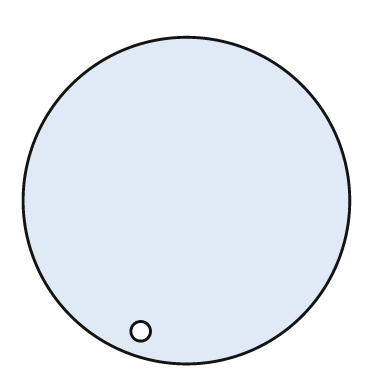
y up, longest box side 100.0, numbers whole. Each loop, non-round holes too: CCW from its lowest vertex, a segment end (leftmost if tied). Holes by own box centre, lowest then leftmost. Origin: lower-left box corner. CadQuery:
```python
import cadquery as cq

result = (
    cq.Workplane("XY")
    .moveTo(50.0, 50.0)
    .circle(50.0)
    .moveTo(36.0, 10.0)
    .circle(3.0)
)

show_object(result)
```